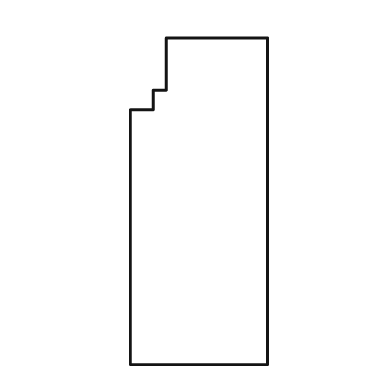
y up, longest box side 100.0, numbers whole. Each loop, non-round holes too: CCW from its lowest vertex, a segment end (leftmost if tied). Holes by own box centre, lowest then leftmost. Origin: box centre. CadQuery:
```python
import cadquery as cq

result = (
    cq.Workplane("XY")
    .moveTo(-21.0, -50.0)
    .lineTo(21.0, -50.0)
    .lineTo(21.0, 50.0)
    .lineTo(-10.0, 50.0)
    .lineTo(-10.0, 34.0)
    .lineTo(-14.0, 34.0)
    .lineTo(-14.0, 28.0)
    .lineTo(-21.0, 28.0)
    .close()
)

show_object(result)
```